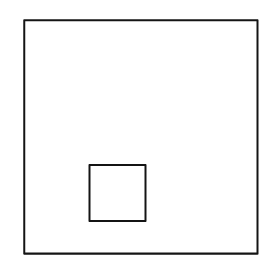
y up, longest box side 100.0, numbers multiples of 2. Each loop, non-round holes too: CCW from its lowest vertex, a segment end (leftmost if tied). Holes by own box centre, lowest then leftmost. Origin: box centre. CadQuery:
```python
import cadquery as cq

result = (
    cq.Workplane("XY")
    .moveTo(-50.0, -50.0)
    .lineTo(50.0, -50.0)
    .lineTo(50.0, 50.0)
    .lineTo(-50.0, 50.0)
    .close()
    .moveTo(-22.0, -36.0)
    .lineTo(2.0, -36.0)
    .lineTo(2.0, -12.0)
    .lineTo(-22.0, -12.0)
    .close()
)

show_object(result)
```